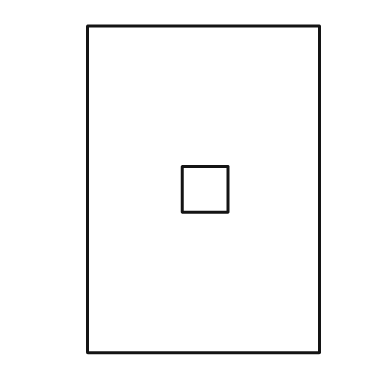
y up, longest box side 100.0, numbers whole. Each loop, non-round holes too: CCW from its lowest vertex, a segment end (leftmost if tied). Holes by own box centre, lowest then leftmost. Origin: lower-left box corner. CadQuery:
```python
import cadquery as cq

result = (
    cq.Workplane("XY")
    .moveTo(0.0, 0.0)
    .lineTo(71.0, 0.0)
    .lineTo(71.0, 100.0)
    .lineTo(0.0, 100.0)
    .close()
    .moveTo(29.0, 43.0)
    .lineTo(43.0, 43.0)
    .lineTo(43.0, 57.0)
    .lineTo(29.0, 57.0)
    .close()
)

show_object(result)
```